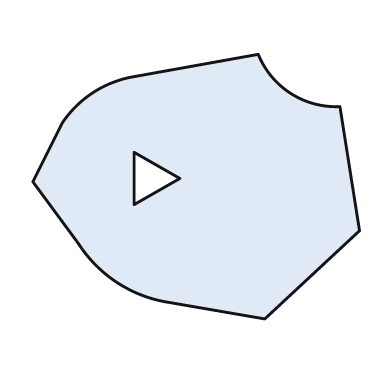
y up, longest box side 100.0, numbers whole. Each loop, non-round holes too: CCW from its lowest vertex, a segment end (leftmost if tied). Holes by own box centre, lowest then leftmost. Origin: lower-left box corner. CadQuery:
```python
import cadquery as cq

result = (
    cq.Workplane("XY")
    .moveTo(71.0, 0.0)
    .lineTo(100.0, 27.0)
    .lineTo(94.0, 65.0)
    .threePointArc((79.0, 69.0), (69.0, 81.0))
    .lineTo(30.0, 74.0)
    .threePointArc((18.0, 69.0), (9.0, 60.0))
    .lineTo(0.0, 42.0)
    .lineTo(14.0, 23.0)
    .threePointArc((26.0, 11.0), (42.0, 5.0))
    .close()
    .moveTo(31.0, 35.0)
    .lineTo(45.0, 43.0)
    .lineTo(31.0, 51.0)
    .close()
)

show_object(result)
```